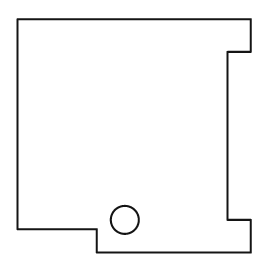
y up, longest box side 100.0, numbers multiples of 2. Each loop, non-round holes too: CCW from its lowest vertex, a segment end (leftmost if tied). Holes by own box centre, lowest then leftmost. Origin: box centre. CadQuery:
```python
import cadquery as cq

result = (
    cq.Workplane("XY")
    .moveTo(-16.0, -50.0)
    .lineTo(50.0, -50.0)
    .lineTo(50.0, -36.0)
    .lineTo(40.0, -36.0)
    .lineTo(40.0, 36.0)
    .lineTo(50.0, 36.0)
    .lineTo(50.0, 50.0)
    .lineTo(-50.0, 50.0)
    .lineTo(-50.0, -40.0)
    .lineTo(-16.0, -40.0)
    .close()
    .moveTo(-4.0, -36.0)
    .circle(6.0)
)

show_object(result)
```